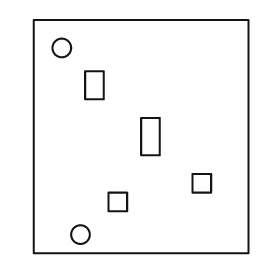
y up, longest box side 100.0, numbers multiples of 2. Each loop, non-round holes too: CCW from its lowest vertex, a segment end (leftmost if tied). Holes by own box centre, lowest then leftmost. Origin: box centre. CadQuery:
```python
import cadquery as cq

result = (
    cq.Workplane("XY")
    .moveTo(-46.0, -50.0)
    .lineTo(46.0, -50.0)
    .lineTo(46.0, 50.0)
    .lineTo(-46.0, 50.0)
    .close()
    .moveTo(-26.0, -42.0)
    .circle(4.0)
    .moveTo(-14.0, -32.0)
    .lineTo(-6.0, -32.0)
    .lineTo(-6.0, -24.0)
    .lineTo(-14.0, -24.0)
    .close()
    .moveTo(22.0, -24.0)
    .lineTo(30.0, -24.0)
    .lineTo(30.0, -16.0)
    .lineTo(22.0, -16.0)
    .close()
    .moveTo(0.0, -8.0)
    .lineTo(8.0, -8.0)
    .lineTo(8.0, 8.0)
    .lineTo(0.0, 8.0)
    .close()
    .moveTo(-24.0, 16.0)
    .lineTo(-16.0, 16.0)
    .lineTo(-16.0, 28.0)
    .lineTo(-24.0, 28.0)
    .close()
    .moveTo(-34.0, 38.0)
    .circle(4.0)
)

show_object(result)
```